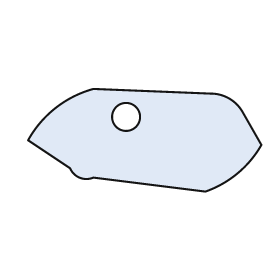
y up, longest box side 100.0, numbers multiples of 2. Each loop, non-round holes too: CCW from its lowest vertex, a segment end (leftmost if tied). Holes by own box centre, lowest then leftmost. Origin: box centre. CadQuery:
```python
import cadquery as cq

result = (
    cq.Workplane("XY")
    .moveTo(26.0, -22.0)
    .threePointArc((40.0, -14.0), (50.0, -2.0))
    .lineTo(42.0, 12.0)
    .threePointArc((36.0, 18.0), (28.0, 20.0))
    .lineTo(-22.0, 22.0)
    .threePointArc((-38.0, 14.0), (-50.0, 0.0))
    .lineTo(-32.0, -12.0)
    .threePointArc((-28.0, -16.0), (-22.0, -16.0))
    .close()
    .moveTo(-8.0, 10.0)
    .circle(6.0)
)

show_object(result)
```